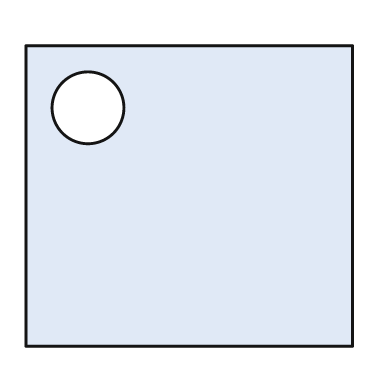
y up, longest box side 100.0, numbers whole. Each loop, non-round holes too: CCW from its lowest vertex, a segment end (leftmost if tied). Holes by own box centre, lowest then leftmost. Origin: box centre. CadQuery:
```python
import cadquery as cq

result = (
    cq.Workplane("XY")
    .moveTo(-50.0, -46.0)
    .lineTo(50.0, -46.0)
    .lineTo(50.0, 46.0)
    .lineTo(-50.0, 46.0)
    .close()
    .moveTo(-31.0, 27.0)
    .circle(11.0)
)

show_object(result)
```